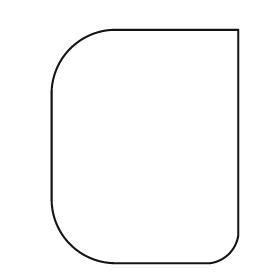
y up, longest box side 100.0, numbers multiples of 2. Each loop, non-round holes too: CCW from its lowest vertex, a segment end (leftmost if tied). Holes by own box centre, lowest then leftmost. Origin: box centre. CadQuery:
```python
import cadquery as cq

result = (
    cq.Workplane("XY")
    .moveTo(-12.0, -50.0)
    .lineTo(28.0, -50.0)
    .threePointArc((36.0, -46.0), (40.0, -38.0))
    .lineTo(40.0, 50.0)
    .lineTo(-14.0, 50.0)
    .threePointArc((-32.0, 42.0), (-40.0, 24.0))
    .lineTo(-40.0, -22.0)
    .threePointArc((-32.0, -42.0), (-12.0, -50.0))
    .close()
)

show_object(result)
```